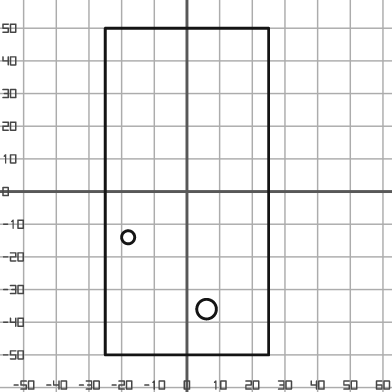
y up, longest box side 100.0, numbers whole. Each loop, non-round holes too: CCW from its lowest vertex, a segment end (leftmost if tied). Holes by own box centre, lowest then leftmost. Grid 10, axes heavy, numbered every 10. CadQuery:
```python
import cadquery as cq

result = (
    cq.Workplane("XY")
    .moveTo(-25.0, -50.0)
    .lineTo(25.0, -50.0)
    .lineTo(25.0, 50.0)
    .lineTo(-25.0, 50.0)
    .close()
    .moveTo(6.0, -36.0)
    .circle(3.0)
    .moveTo(-18.0, -14.0)
    .circle(2.0)
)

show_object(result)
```